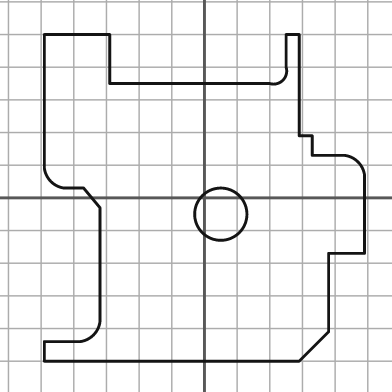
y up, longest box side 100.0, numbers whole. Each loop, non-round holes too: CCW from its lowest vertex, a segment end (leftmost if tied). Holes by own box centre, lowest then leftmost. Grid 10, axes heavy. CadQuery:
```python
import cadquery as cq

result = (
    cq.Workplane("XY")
    .moveTo(-49.0, -50.0)
    .lineTo(29.0, -50.0)
    .lineTo(38.0, -41.0)
    .lineTo(38.0, -17.0)
    .lineTo(49.0, -17.0)
    .lineTo(49.0, 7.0)
    .threePointArc((47.0, 11.0), (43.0, 13.0))
    .lineTo(33.0, 13.0)
    .lineTo(33.0, 19.0)
    .lineTo(29.0, 19.0)
    .lineTo(29.0, 50.0)
    .lineTo(25.0, 50.0)
    .lineTo(25.0, 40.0)
    .threePointArc((24.0, 36.0), (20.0, 35.0))
    .lineTo(-29.0, 35.0)
    .lineTo(-29.0, 50.0)
    .lineTo(-49.0, 50.0)
    .lineTo(-49.0, 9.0)
    .threePointArc((-47.0, 5.0), (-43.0, 3.0))
    .lineTo(-37.0, 3.0)
    .lineTo(-32.0, -3.0)
    .lineTo(-32.0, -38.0)
    .threePointArc((-34.0, -42.0), (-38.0, -44.0))
    .lineTo(-49.0, -44.0)
    .close()
    .moveTo(5.0, -5.0)
    .circle(8.0)
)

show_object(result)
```